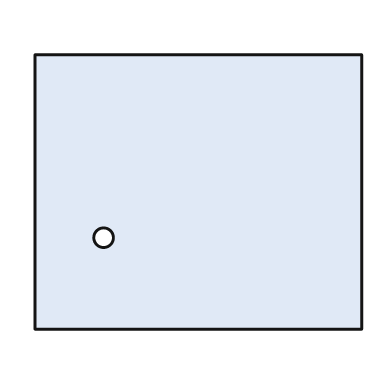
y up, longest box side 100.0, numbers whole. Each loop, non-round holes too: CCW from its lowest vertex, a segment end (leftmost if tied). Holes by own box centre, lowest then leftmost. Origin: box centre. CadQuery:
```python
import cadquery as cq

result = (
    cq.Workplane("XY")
    .moveTo(-50.0, -42.0)
    .lineTo(50.0, -42.0)
    .lineTo(50.0, 42.0)
    .lineTo(-50.0, 42.0)
    .close()
    .moveTo(-29.0, -14.0)
    .circle(3.0)
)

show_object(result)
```